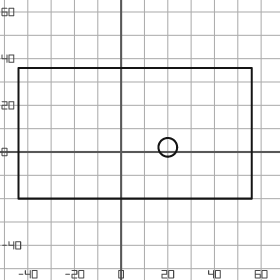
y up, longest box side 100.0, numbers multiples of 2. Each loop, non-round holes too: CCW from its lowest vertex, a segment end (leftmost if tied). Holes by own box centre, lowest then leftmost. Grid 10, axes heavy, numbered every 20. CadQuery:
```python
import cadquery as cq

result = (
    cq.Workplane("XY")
    .moveTo(-44.0, -20.0)
    .lineTo(56.0, -20.0)
    .lineTo(56.0, 36.0)
    .lineTo(-44.0, 36.0)
    .close()
    .moveTo(20.0, 2.0)
    .circle(4.0)
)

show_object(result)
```